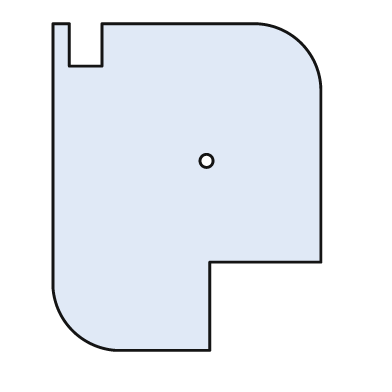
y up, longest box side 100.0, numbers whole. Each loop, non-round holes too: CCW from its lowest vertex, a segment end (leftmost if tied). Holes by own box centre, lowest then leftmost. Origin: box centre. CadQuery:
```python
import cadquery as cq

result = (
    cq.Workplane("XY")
    .moveTo(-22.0, -50.0)
    .lineTo(7.0, -50.0)
    .lineTo(7.0, -23.0)
    .lineTo(41.0, -23.0)
    .lineTo(41.0, 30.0)
    .threePointArc((35.0, 44.0), (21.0, 50.0))
    .lineTo(-26.0, 50.0)
    .lineTo(-26.0, 37.0)
    .lineTo(-36.0, 37.0)
    .lineTo(-36.0, 50.0)
    .lineTo(-41.0, 50.0)
    .lineTo(-41.0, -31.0)
    .threePointArc((-35.0, -44.0), (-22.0, -50.0))
    .close()
    .moveTo(6.0, 8.0)
    .circle(2.0)
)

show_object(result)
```